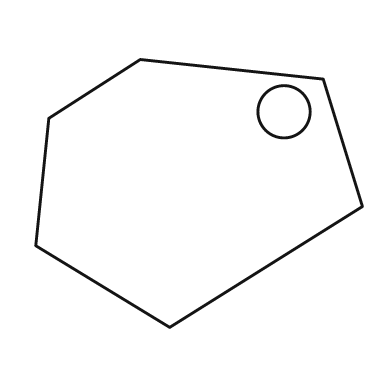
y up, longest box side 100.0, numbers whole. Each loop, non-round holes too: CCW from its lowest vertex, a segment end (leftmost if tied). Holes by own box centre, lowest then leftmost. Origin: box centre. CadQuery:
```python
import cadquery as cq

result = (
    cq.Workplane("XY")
    .moveTo(-9.0, -41.0)
    .lineTo(50.0, -4.0)
    .lineTo(38.0, 35.0)
    .lineTo(-18.0, 41.0)
    .lineTo(-46.0, 23.0)
    .lineTo(-50.0, -16.0)
    .close()
    .moveTo(26.0, 25.0)
    .circle(8.0)
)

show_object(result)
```